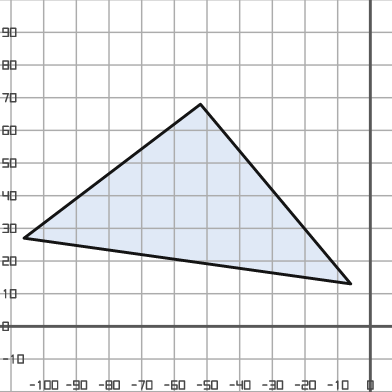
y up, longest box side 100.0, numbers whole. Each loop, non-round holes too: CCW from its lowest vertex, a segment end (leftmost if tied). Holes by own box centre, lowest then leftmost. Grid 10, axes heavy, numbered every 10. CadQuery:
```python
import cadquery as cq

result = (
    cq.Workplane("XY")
    .moveTo(-6.0, 13.0)
    .lineTo(-52.0, 68.0)
    .lineTo(-106.0, 27.0)
    .close()
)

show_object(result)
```